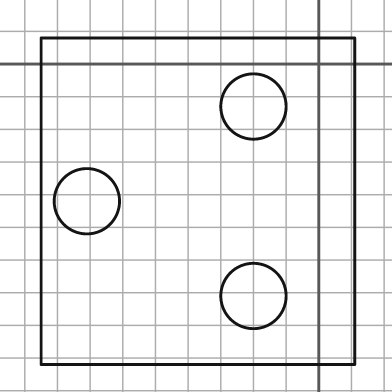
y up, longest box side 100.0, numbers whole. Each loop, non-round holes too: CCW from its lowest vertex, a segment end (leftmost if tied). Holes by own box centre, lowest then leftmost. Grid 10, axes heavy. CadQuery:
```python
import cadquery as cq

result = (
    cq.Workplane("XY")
    .moveTo(-85.0, -92.0)
    .lineTo(11.0, -92.0)
    .lineTo(11.0, 8.0)
    .lineTo(-85.0, 8.0)
    .close()
    .moveTo(-20.0, -71.0)
    .circle(10.0)
    .moveTo(-71.0, -42.0)
    .circle(10.0)
    .moveTo(-20.0, -13.0)
    .circle(10.0)
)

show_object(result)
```